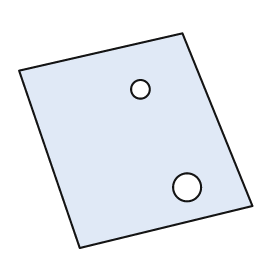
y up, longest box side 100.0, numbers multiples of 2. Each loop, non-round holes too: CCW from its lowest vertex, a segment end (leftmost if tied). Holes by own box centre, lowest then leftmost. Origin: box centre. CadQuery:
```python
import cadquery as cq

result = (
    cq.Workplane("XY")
    .moveTo(-24.0, -46.0)
    .lineTo(50.0, -28.0)
    .lineTo(20.0, 46.0)
    .lineTo(-50.0, 30.0)
    .close()
    .moveTo(22.0, -20.0)
    .circle(6.0)
    .moveTo(2.0, 22.0)
    .circle(4.0)
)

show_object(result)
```